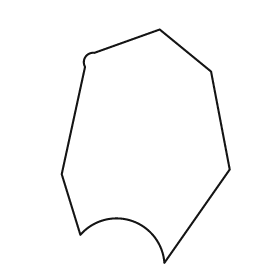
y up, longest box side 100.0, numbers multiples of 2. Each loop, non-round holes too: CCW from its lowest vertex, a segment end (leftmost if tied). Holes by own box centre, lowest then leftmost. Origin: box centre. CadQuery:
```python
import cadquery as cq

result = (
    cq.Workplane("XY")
    .moveTo(8.0, -50.0)
    .lineTo(36.0, -10.0)
    .lineTo(28.0, 32.0)
    .lineTo(6.0, 50.0)
    .lineTo(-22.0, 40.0)
    .threePointArc((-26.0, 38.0), (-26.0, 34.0))
    .lineTo(-36.0, -12.0)
    .lineTo(-28.0, -38.0)
    .threePointArc((-6.0, -32.0), (8.0, -50.0))
    .close()
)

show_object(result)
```